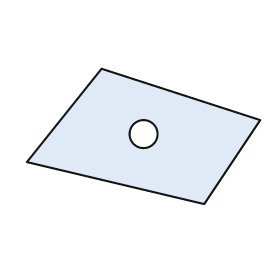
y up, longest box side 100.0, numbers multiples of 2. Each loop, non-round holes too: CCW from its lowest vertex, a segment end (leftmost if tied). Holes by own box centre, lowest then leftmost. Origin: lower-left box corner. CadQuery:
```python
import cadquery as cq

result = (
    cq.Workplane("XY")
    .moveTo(76.0, 0.0)
    .lineTo(100.0, 36.0)
    .lineTo(32.0, 58.0)
    .lineTo(0.0, 18.0)
    .close()
    .moveTo(50.0, 30.0)
    .circle(6.0)
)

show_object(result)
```